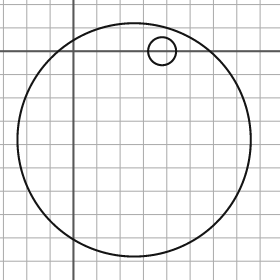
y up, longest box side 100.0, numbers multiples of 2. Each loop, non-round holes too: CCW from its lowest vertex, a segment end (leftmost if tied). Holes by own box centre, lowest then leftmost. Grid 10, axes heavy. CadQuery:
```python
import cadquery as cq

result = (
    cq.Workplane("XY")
    .moveTo(26.0, -38.0)
    .circle(50.0)
    .moveTo(38.0, 0.0)
    .circle(6.0)
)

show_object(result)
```